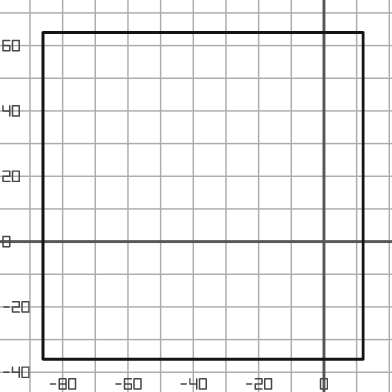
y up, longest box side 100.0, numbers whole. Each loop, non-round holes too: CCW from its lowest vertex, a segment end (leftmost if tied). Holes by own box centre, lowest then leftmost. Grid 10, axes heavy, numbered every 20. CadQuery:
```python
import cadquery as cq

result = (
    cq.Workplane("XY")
    .moveTo(-86.0, -36.0)
    .lineTo(12.0, -36.0)
    .lineTo(12.0, 64.0)
    .lineTo(-86.0, 64.0)
    .close()
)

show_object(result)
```